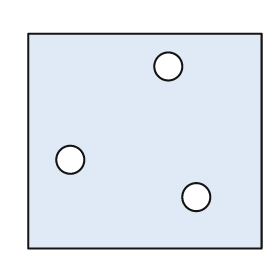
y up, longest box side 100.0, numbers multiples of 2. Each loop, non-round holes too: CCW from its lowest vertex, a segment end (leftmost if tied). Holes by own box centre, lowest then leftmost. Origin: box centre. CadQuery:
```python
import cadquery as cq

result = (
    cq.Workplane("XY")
    .moveTo(-50.0, -46.0)
    .lineTo(50.0, -46.0)
    .lineTo(50.0, 46.0)
    .lineTo(-50.0, 46.0)
    .close()
    .moveTo(22.0, -24.0)
    .circle(6.0)
    .moveTo(-32.0, -8.0)
    .circle(6.0)
    .moveTo(10.0, 32.0)
    .circle(6.0)
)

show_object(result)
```